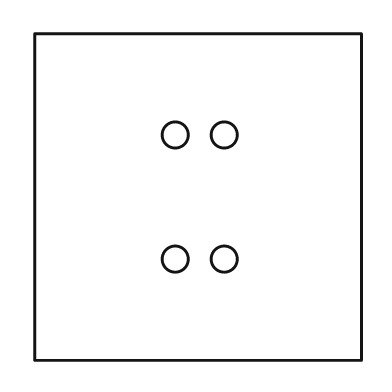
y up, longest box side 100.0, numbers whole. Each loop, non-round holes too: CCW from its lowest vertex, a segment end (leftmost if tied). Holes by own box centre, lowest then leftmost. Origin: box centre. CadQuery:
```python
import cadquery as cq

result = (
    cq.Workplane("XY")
    .moveTo(-50.0, -50.0)
    .lineTo(50.0, -50.0)
    .lineTo(50.0, 50.0)
    .lineTo(-50.0, 50.0)
    .close()
    .moveTo(-7.0, -19.0)
    .circle(4.0)
    .moveTo(8.0, -19.0)
    .circle(4.0)
    .moveTo(-7.0, 19.0)
    .circle(4.0)
    .moveTo(8.0, 19.0)
    .circle(4.0)
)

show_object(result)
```